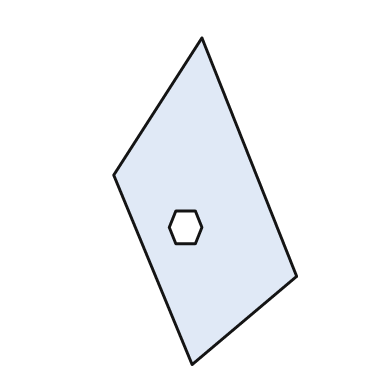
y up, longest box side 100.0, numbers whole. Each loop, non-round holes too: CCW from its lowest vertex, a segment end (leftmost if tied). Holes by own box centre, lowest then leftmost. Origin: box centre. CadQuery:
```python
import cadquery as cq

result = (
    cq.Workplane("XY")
    .moveTo(-4.0, -50.0)
    .lineTo(28.0, -23.0)
    .lineTo(-1.0, 50.0)
    .lineTo(-28.0, 8.0)
    .close()
    .moveTo(-9.0, -13.0)
    .lineTo(-3.0, -13.0)
    .lineTo(-1.0, -8.0)
    .lineTo(-3.0, -3.0)
    .lineTo(-9.0, -3.0)
    .lineTo(-11.0, -8.0)
    .close()
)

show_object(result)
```